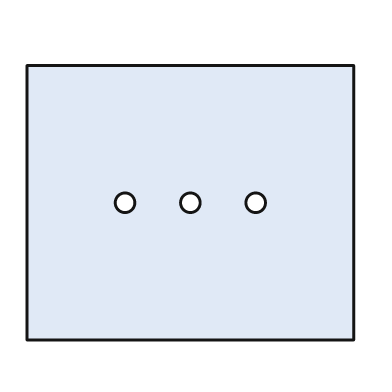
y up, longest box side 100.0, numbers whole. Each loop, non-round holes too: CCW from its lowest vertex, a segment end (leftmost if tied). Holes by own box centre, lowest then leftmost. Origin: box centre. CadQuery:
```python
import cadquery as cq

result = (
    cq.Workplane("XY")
    .moveTo(-50.0, -42.0)
    .lineTo(50.0, -42.0)
    .lineTo(50.0, 42.0)
    .lineTo(-50.0, 42.0)
    .close()
    .moveTo(-20.0, 0.0)
    .circle(3.0)
    .moveTo(0.0, 0.0)
    .circle(3.0)
    .moveTo(20.0, 0.0)
    .circle(3.0)
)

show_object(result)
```